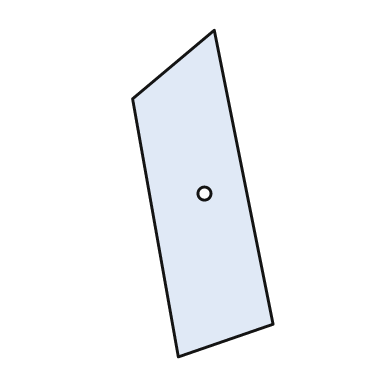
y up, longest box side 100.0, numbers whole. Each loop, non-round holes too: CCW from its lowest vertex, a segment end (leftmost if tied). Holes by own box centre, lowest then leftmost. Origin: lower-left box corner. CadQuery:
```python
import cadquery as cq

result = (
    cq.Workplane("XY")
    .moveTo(14.0, 0.0)
    .lineTo(43.0, 10.0)
    .lineTo(25.0, 100.0)
    .lineTo(0.0, 79.0)
    .close()
    .moveTo(22.0, 50.0)
    .circle(2.0)
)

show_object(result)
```